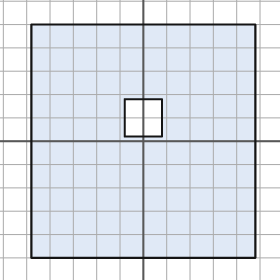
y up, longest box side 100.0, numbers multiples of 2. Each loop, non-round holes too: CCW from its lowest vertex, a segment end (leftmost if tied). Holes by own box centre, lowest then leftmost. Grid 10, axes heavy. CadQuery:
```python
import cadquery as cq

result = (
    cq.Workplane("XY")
    .moveTo(-48.0, -50.0)
    .lineTo(48.0, -50.0)
    .lineTo(48.0, 50.0)
    .lineTo(-48.0, 50.0)
    .close()
    .moveTo(-8.0, 2.0)
    .lineTo(8.0, 2.0)
    .lineTo(8.0, 18.0)
    .lineTo(-8.0, 18.0)
    .close()
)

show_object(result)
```